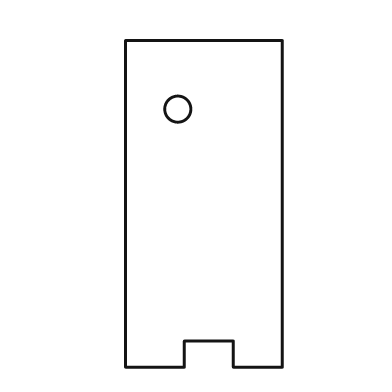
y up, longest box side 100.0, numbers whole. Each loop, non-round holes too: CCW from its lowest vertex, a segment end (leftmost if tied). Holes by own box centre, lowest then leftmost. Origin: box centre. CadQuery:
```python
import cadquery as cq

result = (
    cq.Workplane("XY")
    .moveTo(-24.0, -50.0)
    .lineTo(-6.0, -50.0)
    .lineTo(-6.0, -42.0)
    .lineTo(9.0, -42.0)
    .lineTo(9.0, -50.0)
    .lineTo(24.0, -50.0)
    .lineTo(24.0, 50.0)
    .lineTo(-24.0, 50.0)
    .close()
    .moveTo(-8.0, 29.0)
    .circle(4.0)
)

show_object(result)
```